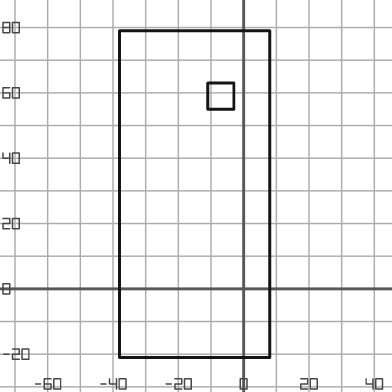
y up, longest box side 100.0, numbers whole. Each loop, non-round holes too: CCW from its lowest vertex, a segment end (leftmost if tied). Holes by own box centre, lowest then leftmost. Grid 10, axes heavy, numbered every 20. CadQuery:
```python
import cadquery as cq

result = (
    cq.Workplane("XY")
    .moveTo(-38.0, -21.0)
    .lineTo(8.0, -21.0)
    .lineTo(8.0, 79.0)
    .lineTo(-38.0, 79.0)
    .close()
    .moveTo(-11.0, 55.0)
    .lineTo(-3.0, 55.0)
    .lineTo(-3.0, 63.0)
    .lineTo(-11.0, 63.0)
    .close()
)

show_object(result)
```